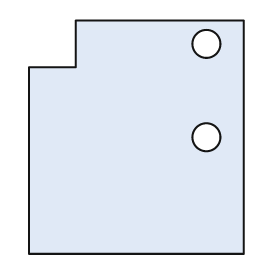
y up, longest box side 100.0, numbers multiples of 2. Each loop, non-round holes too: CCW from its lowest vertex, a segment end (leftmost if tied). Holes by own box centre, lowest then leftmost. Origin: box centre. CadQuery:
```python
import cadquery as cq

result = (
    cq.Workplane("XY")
    .moveTo(-46.0, -50.0)
    .lineTo(46.0, -50.0)
    .lineTo(46.0, 50.0)
    .lineTo(-26.0, 50.0)
    .lineTo(-26.0, 30.0)
    .lineTo(-46.0, 30.0)
    .close()
    .moveTo(30.0, 0.0)
    .circle(6.0)
    .moveTo(30.0, 40.0)
    .circle(6.0)
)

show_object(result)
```